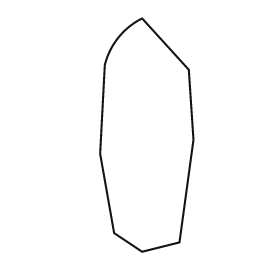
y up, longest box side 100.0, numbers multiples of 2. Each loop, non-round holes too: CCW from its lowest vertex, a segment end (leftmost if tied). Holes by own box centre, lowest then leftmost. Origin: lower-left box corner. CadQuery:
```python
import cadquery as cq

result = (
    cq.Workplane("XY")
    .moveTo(18.0, 0.0)
    .lineTo(34.0, 4.0)
    .lineTo(40.0, 48.0)
    .lineTo(38.0, 78.0)
    .lineTo(18.0, 100.0)
    .threePointArc((8.0, 92.0), (2.0, 80.0))
    .lineTo(0.0, 42.0)
    .lineTo(6.0, 8.0)
    .close()
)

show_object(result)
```